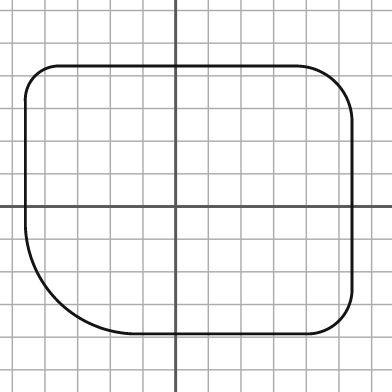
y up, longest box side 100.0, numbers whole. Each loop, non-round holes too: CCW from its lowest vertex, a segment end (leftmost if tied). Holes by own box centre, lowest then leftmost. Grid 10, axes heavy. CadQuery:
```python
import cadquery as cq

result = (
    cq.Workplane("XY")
    .moveTo(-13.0, -39.0)
    .lineTo(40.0, -39.0)
    .threePointArc((50.0, -35.0), (54.0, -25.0))
    .lineTo(54.0, 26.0)
    .threePointArc((49.0, 38.0), (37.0, 43.0))
    .lineTo(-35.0, 43.0)
    .threePointArc((-43.0, 40.0), (-46.0, 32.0))
    .lineTo(-46.0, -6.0)
    .threePointArc((-36.0, -29.0), (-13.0, -39.0))
    .close()
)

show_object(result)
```